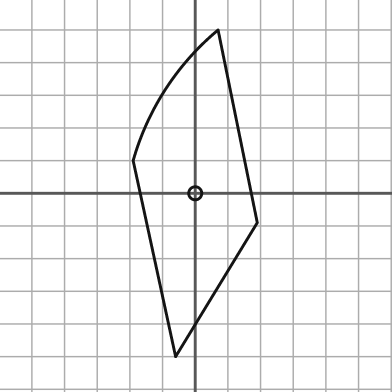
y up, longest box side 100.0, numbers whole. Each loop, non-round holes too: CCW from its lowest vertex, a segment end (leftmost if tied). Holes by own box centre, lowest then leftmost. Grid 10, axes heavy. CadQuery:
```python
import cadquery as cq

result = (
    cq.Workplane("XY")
    .moveTo(-6.0, -50.0)
    .lineTo(19.0, -9.0)
    .lineTo(7.0, 50.0)
    .threePointArc((-9.0, 32.0), (-19.0, 10.0))
    .close()
    .moveTo(0.0, 0.0)
    .circle(2.0)
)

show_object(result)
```